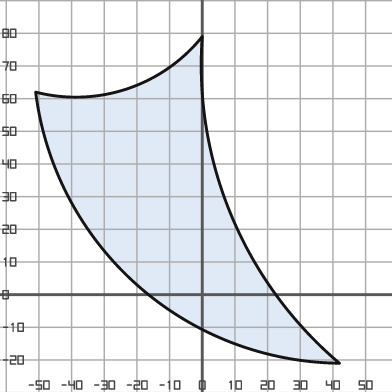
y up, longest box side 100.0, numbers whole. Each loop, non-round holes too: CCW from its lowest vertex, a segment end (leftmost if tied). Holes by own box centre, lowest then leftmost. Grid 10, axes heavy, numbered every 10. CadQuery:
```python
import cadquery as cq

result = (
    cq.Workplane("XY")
    .moveTo(42.0, -21.0)
    .threePointArc((9.0, 24.0), (0.0, 79.0))
    .threePointArc((-23.0, 63.0), (-51.0, 62.0))
    .threePointArc((-20.0, 3.0), (42.0, -21.0))
    .close()
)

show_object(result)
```